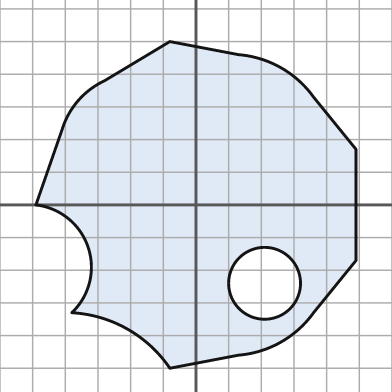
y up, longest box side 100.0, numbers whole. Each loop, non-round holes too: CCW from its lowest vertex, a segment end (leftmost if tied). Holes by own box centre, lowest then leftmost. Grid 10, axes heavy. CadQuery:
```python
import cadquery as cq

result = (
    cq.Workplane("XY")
    .moveTo(-8.0, -50.0)
    .lineTo(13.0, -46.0)
    .threePointArc((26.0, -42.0), (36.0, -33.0))
    .lineTo(49.0, -17.0)
    .lineTo(49.0, 17.0)
    .lineTo(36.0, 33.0)
    .threePointArc((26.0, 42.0), (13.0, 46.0))
    .lineTo(-8.0, 50.0)
    .lineTo(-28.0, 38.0)
    .threePointArc((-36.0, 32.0), (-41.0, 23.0))
    .lineTo(-49.0, 0.0)
    .threePointArc((-33.0, -13.0), (-38.0, -33.0))
    .threePointArc((-21.0, -38.0), (-8.0, -50.0))
    .close()
    .moveTo(21.0, -24.0)
    .circle(11.0)
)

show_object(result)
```